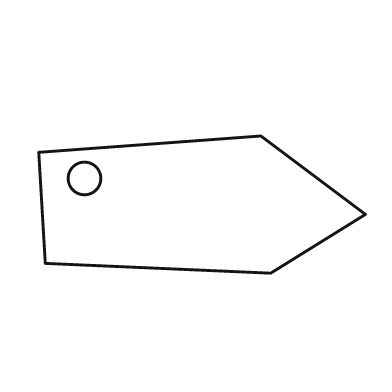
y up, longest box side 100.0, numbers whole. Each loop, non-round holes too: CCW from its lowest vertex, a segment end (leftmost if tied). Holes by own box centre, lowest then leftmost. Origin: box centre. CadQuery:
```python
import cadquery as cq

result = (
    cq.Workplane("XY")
    .moveTo(21.0, -21.0)
    .lineTo(50.0, -3.0)
    .lineTo(18.0, 21.0)
    .lineTo(-50.0, 16.0)
    .lineTo(-48.0, -18.0)
    .close()
    .moveTo(-36.0, 8.0)
    .circle(5.0)
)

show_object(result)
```